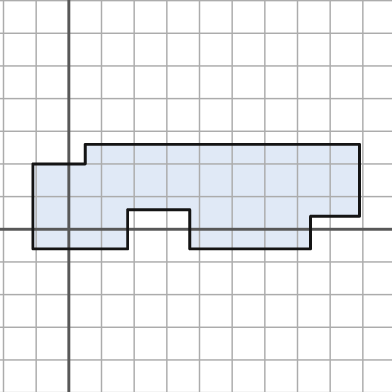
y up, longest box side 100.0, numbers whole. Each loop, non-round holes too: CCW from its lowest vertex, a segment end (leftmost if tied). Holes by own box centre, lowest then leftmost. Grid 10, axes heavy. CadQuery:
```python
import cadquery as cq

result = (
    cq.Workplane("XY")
    .moveTo(-11.0, -6.0)
    .lineTo(18.0, -6.0)
    .lineTo(18.0, 6.0)
    .lineTo(37.0, 6.0)
    .lineTo(37.0, -6.0)
    .lineTo(74.0, -6.0)
    .lineTo(74.0, 4.0)
    .lineTo(89.0, 4.0)
    .lineTo(89.0, 26.0)
    .lineTo(5.0, 26.0)
    .lineTo(5.0, 20.0)
    .lineTo(-11.0, 20.0)
    .close()
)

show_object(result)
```